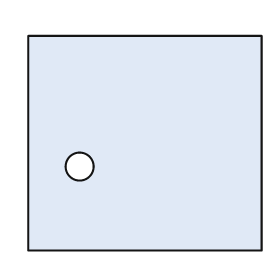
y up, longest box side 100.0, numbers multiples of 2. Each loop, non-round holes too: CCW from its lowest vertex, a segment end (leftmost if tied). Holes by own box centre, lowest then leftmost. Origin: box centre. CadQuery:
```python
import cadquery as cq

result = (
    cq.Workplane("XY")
    .moveTo(-50.0, -46.0)
    .lineTo(50.0, -46.0)
    .lineTo(50.0, 46.0)
    .lineTo(-50.0, 46.0)
    .close()
    .moveTo(-28.0, -10.0)
    .circle(6.0)
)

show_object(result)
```